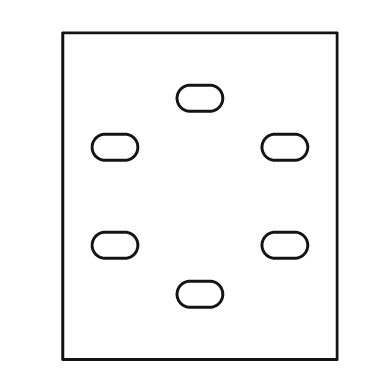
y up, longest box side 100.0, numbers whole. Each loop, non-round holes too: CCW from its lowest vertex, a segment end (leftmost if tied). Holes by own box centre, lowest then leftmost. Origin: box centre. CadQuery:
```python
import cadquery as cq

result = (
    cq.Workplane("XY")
    .moveTo(-42.0, -50.0)
    .lineTo(42.0, -50.0)
    .lineTo(42.0, 50.0)
    .lineTo(-42.0, 50.0)
    .close()
    .moveTo(-3.0, -34.0)
    .lineTo(3.0, -34.0)
    .threePointArc((7.0, -30.0), (3.0, -26.0))
    .lineTo(-3.0, -26.0)
    .threePointArc((-7.0, -30.0), (-3.0, -34.0))
    .close()
    .moveTo(-29.0, -19.0)
    .lineTo(-23.0, -19.0)
    .threePointArc((-19.0, -15.0), (-23.0, -11.0))
    .lineTo(-29.0, -11.0)
    .threePointArc((-33.0, -15.0), (-29.0, -19.0))
    .close()
    .moveTo(23.0, -19.0)
    .lineTo(29.0, -19.0)
    .threePointArc((33.0, -15.0), (29.0, -11.0))
    .lineTo(23.0, -11.0)
    .threePointArc((19.0, -15.0), (23.0, -19.0))
    .close()
    .moveTo(-29.0, 11.0)
    .lineTo(-23.0, 11.0)
    .threePointArc((-19.0, 15.0), (-23.0, 19.0))
    .lineTo(-29.0, 19.0)
    .threePointArc((-33.0, 15.0), (-29.0, 11.0))
    .close()
    .moveTo(23.0, 11.0)
    .lineTo(29.0, 11.0)
    .threePointArc((33.0, 15.0), (29.0, 19.0))
    .lineTo(23.0, 19.0)
    .threePointArc((19.0, 15.0), (23.0, 11.0))
    .close()
    .moveTo(-3.0, 26.0)
    .lineTo(3.0, 26.0)
    .threePointArc((7.0, 30.0), (3.0, 34.0))
    .lineTo(-3.0, 34.0)
    .threePointArc((-7.0, 30.0), (-3.0, 26.0))
    .close()
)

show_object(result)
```